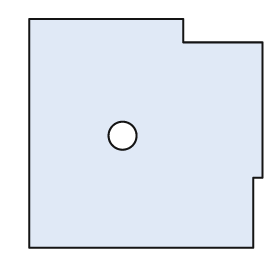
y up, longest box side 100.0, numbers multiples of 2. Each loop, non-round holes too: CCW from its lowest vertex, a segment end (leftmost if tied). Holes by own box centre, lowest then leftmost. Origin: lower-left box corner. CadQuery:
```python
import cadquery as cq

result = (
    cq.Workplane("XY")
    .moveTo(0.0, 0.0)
    .lineTo(96.0, 0.0)
    .lineTo(96.0, 30.0)
    .lineTo(100.0, 30.0)
    .lineTo(100.0, 88.0)
    .lineTo(66.0, 88.0)
    .lineTo(66.0, 98.0)
    .lineTo(0.0, 98.0)
    .close()
    .moveTo(40.0, 48.0)
    .circle(6.0)
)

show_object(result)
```